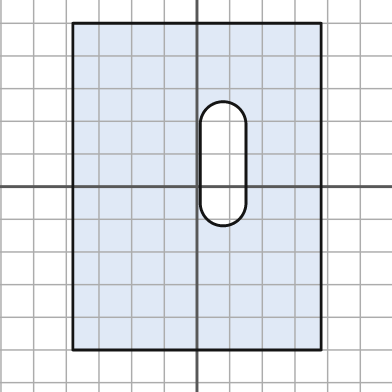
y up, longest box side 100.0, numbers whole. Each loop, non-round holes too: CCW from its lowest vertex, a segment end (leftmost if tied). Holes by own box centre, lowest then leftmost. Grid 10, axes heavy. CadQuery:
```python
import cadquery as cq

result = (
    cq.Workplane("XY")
    .moveTo(-38.0, -50.0)
    .lineTo(38.0, -50.0)
    .lineTo(38.0, 50.0)
    .lineTo(-38.0, 50.0)
    .close()
    .moveTo(1.0, -5.0)
    .threePointArc((8.0, -12.0), (15.0, -5.0))
    .lineTo(15.0, 19.0)
    .threePointArc((8.0, 26.0), (1.0, 19.0))
    .close()
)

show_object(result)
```